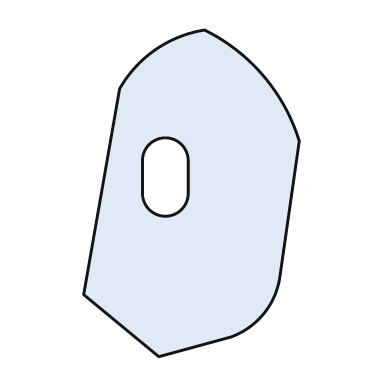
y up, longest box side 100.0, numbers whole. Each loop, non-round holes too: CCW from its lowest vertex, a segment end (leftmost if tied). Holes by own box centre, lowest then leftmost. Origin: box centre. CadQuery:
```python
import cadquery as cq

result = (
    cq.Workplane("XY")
    .moveTo(-10.0, -50.0)
    .lineTo(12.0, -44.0)
    .threePointArc((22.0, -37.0), (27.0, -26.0))
    .lineTo(33.0, 16.0)
    .threePointArc((22.0, 36.0), (4.0, 50.0))
    .threePointArc((-11.0, 44.0), (-22.0, 32.0))
    .lineTo(-33.0, -31.0)
    .close()
    .moveTo(-15.0, 0.0)
    .threePointArc((-8.0, -7.0), (-1.0, 0.0))
    .lineTo(-1.0, 10.0)
    .threePointArc((-8.0, 17.0), (-15.0, 10.0))
    .close()
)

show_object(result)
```